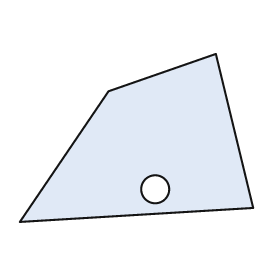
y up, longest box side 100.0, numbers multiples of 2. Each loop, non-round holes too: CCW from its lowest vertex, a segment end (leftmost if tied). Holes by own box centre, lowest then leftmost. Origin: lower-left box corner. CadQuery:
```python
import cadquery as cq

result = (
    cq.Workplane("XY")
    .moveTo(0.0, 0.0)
    .lineTo(100.0, 6.0)
    .lineTo(84.0, 72.0)
    .lineTo(38.0, 56.0)
    .close()
    .moveTo(58.0, 14.0)
    .circle(6.0)
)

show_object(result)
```